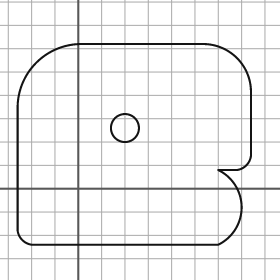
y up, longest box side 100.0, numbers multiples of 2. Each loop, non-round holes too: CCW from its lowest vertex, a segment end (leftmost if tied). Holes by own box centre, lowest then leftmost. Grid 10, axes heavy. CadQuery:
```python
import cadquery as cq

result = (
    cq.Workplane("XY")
    .moveTo(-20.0, -24.0)
    .lineTo(60.0, -24.0)
    .threePointArc((70.0, -8.0), (60.0, 8.0))
    .lineTo(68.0, 8.0)
    .threePointArc((72.0, 10.0), (74.0, 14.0))
    .lineTo(74.0, 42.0)
    .threePointArc((68.0, 56.0), (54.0, 62.0))
    .lineTo(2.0, 62.0)
    .threePointArc((-18.0, 54.0), (-26.0, 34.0))
    .lineTo(-26.0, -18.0)
    .threePointArc((-24.0, -22.0), (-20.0, -24.0))
    .close()
    .moveTo(20.0, 26.0)
    .circle(6.0)
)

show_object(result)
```